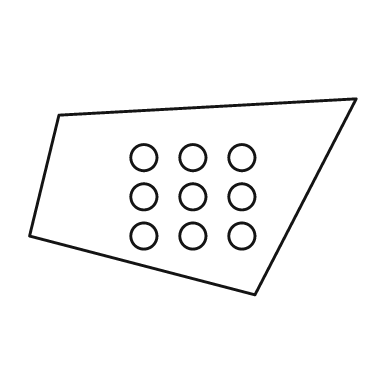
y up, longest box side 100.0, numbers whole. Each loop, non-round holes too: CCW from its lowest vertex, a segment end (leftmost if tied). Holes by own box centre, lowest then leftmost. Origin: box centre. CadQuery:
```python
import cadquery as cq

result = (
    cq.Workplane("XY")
    .moveTo(19.0, -30.0)
    .lineTo(50.0, 30.0)
    .lineTo(-41.0, 25.0)
    .lineTo(-50.0, -12.0)
    .close()
    .moveTo(-15.0, -12.0)
    .circle(4.0)
    .moveTo(0.0, -12.0)
    .circle(4.0)
    .moveTo(15.0, -12.0)
    .circle(4.0)
    .moveTo(-15.0, 0.0)
    .circle(4.0)
    .moveTo(0.0, 0.0)
    .circle(4.0)
    .moveTo(15.0, 0.0)
    .circle(4.0)
    .moveTo(-15.0, 12.0)
    .circle(4.0)
    .moveTo(0.0, 12.0)
    .circle(4.0)
    .moveTo(15.0, 12.0)
    .circle(4.0)
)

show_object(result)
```